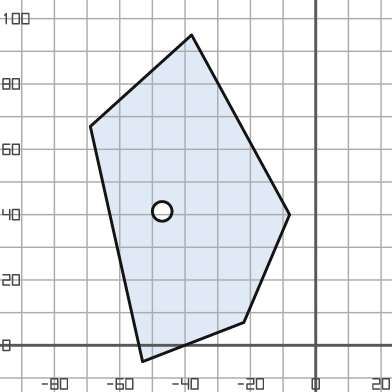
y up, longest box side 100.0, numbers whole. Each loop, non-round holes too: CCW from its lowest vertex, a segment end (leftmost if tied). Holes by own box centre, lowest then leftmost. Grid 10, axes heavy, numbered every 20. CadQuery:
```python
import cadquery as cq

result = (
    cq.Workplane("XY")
    .moveTo(-53.0, -5.0)
    .lineTo(-22.0, 7.0)
    .lineTo(-8.0, 40.0)
    .lineTo(-38.0, 95.0)
    .lineTo(-69.0, 67.0)
    .close()
    .moveTo(-47.0, 41.0)
    .circle(3.0)
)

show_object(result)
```